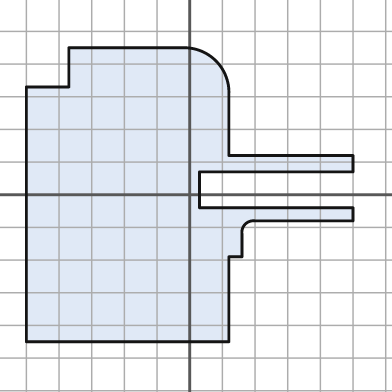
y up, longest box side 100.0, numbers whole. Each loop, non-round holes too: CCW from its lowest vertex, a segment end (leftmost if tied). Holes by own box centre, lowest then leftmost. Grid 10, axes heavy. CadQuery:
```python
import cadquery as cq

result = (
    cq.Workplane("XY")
    .moveTo(-50.0, -45.0)
    .lineTo(12.0, -45.0)
    .lineTo(12.0, -19.0)
    .lineTo(16.0, -19.0)
    .lineTo(16.0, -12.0)
    .threePointArc((17.0, -9.0), (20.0, -8.0))
    .lineTo(50.0, -8.0)
    .lineTo(50.0, -4.0)
    .lineTo(3.0, -4.0)
    .lineTo(3.0, 7.0)
    .lineTo(50.0, 7.0)
    .lineTo(50.0, 12.0)
    .lineTo(12.0, 12.0)
    .lineTo(12.0, 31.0)
    .threePointArc((8.0, 41.0), (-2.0, 45.0))
    .lineTo(-37.0, 45.0)
    .lineTo(-37.0, 33.0)
    .lineTo(-50.0, 33.0)
    .close()
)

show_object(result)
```